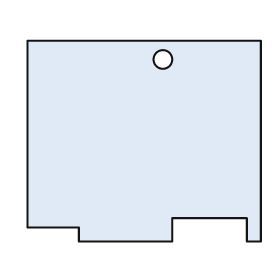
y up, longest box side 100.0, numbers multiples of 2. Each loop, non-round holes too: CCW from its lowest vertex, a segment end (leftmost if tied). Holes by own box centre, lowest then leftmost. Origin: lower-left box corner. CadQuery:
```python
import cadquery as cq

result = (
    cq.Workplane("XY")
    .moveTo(22.0, 0.0)
    .lineTo(62.0, 0.0)
    .lineTo(62.0, 10.0)
    .lineTo(94.0, 10.0)
    .lineTo(94.0, 0.0)
    .lineTo(100.0, 0.0)
    .lineTo(100.0, 86.0)
    .lineTo(0.0, 86.0)
    .lineTo(0.0, 6.0)
    .lineTo(22.0, 6.0)
    .close()
    .moveTo(58.0, 78.0)
    .circle(4.0)
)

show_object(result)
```